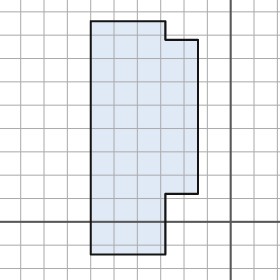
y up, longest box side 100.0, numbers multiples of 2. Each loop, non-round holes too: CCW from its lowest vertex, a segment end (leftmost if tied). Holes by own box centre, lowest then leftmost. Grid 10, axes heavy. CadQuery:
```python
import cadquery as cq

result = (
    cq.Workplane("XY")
    .moveTo(-60.0, -14.0)
    .lineTo(-28.0, -14.0)
    .lineTo(-28.0, 12.0)
    .lineTo(-14.0, 12.0)
    .lineTo(-14.0, 78.0)
    .lineTo(-28.0, 78.0)
    .lineTo(-28.0, 86.0)
    .lineTo(-60.0, 86.0)
    .close()
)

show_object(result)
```